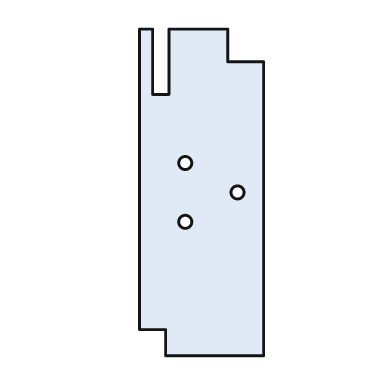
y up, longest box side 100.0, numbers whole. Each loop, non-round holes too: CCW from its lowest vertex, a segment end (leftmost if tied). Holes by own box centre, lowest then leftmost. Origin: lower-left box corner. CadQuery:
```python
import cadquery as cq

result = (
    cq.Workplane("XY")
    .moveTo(8.0, 0.0)
    .lineTo(38.0, 0.0)
    .lineTo(38.0, 90.0)
    .lineTo(27.0, 90.0)
    .lineTo(27.0, 100.0)
    .lineTo(9.0, 100.0)
    .lineTo(9.0, 80.0)
    .lineTo(4.0, 80.0)
    .lineTo(4.0, 100.0)
    .lineTo(0.0, 100.0)
    .lineTo(0.0, 8.0)
    .lineTo(8.0, 8.0)
    .close()
    .moveTo(14.0, 41.0)
    .circle(2.0)
    .moveTo(30.0, 50.0)
    .circle(2.0)
    .moveTo(14.0, 59.0)
    .circle(2.0)
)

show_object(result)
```